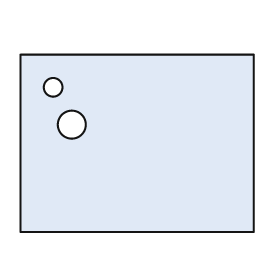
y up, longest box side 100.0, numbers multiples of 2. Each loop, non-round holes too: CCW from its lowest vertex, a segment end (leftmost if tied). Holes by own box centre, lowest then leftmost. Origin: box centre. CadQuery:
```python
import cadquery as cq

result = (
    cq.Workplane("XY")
    .moveTo(-50.0, -38.0)
    .lineTo(50.0, -38.0)
    .lineTo(50.0, 38.0)
    .lineTo(-50.0, 38.0)
    .close()
    .moveTo(-28.0, 8.0)
    .circle(6.0)
    .moveTo(-36.0, 24.0)
    .circle(4.0)
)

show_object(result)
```